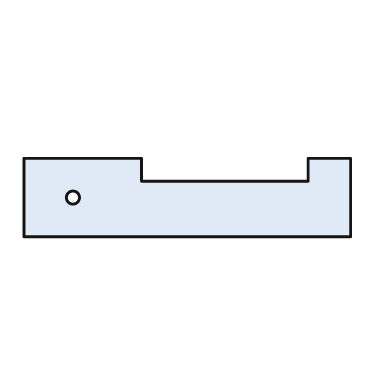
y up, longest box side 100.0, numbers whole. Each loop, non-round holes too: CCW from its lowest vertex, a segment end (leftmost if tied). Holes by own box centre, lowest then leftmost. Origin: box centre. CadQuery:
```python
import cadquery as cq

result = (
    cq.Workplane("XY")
    .moveTo(-50.0, -12.0)
    .lineTo(50.0, -12.0)
    .lineTo(50.0, 12.0)
    .lineTo(37.0, 12.0)
    .lineTo(37.0, 5.0)
    .lineTo(-14.0, 5.0)
    .lineTo(-14.0, 12.0)
    .lineTo(-50.0, 12.0)
    .close()
    .moveTo(-35.0, 0.0)
    .circle(2.0)
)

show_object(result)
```